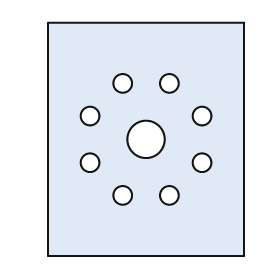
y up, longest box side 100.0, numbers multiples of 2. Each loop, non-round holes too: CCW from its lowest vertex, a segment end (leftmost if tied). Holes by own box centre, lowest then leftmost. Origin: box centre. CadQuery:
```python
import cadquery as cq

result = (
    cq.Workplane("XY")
    .moveTo(-42.0, -50.0)
    .lineTo(42.0, -50.0)
    .lineTo(42.0, 50.0)
    .lineTo(-42.0, 50.0)
    .close()
    .moveTo(-10.0, -24.0)
    .circle(4.0)
    .moveTo(10.0, -24.0)
    .circle(4.0)
    .moveTo(-24.0, -10.0)
    .circle(4.0)
    .moveTo(24.0, -10.0)
    .circle(4.0)
    .moveTo(0.0, 0.0)
    .circle(8.0)
    .moveTo(-24.0, 10.0)
    .circle(4.0)
    .moveTo(24.0, 10.0)
    .circle(4.0)
    .moveTo(-10.0, 24.0)
    .circle(4.0)
    .moveTo(10.0, 24.0)
    .circle(4.0)
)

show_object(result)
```